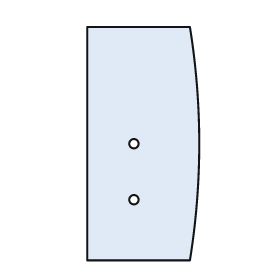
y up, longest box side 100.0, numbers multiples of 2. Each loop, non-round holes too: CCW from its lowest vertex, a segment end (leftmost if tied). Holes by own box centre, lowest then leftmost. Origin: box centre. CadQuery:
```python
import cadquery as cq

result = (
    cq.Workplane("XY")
    .moveTo(-24.0, -50.0)
    .lineTo(20.0, -50.0)
    .threePointArc((24.0, 0.0), (20.0, 50.0))
    .lineTo(-24.0, 50.0)
    .close()
    .moveTo(-4.0, -24.0)
    .circle(2.0)
    .moveTo(-4.0, 0.0)
    .circle(2.0)
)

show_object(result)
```